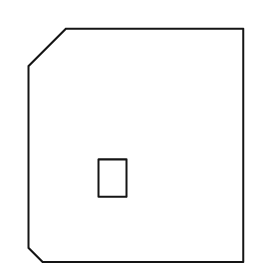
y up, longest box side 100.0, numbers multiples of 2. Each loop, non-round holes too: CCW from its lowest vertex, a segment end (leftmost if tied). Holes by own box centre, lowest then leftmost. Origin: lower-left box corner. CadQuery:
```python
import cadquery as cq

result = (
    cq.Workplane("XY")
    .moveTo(6.0, 0.0)
    .lineTo(92.0, 0.0)
    .lineTo(92.0, 100.0)
    .lineTo(16.0, 100.0)
    .lineTo(0.0, 84.0)
    .lineTo(0.0, 6.0)
    .close()
    .moveTo(30.0, 28.0)
    .lineTo(42.0, 28.0)
    .lineTo(42.0, 44.0)
    .lineTo(30.0, 44.0)
    .close()
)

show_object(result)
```